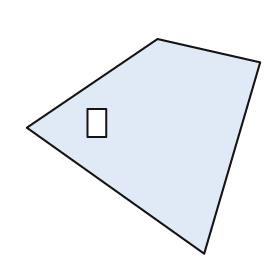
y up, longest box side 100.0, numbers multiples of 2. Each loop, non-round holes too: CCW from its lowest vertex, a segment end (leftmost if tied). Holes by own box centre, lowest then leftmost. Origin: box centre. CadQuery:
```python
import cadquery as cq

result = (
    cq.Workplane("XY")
    .moveTo(26.0, -46.0)
    .lineTo(50.0, 36.0)
    .lineTo(6.0, 46.0)
    .lineTo(-50.0, 8.0)
    .close()
    .moveTo(-24.0, 4.0)
    .lineTo(-16.0, 4.0)
    .lineTo(-16.0, 16.0)
    .lineTo(-24.0, 16.0)
    .close()
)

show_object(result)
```